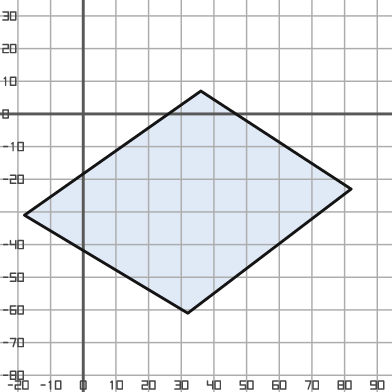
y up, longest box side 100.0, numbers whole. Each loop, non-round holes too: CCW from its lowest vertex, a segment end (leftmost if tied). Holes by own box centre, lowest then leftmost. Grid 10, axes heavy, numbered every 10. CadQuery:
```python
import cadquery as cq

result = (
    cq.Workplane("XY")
    .moveTo(32.0, -61.0)
    .lineTo(82.0, -23.0)
    .lineTo(36.0, 7.0)
    .lineTo(-18.0, -31.0)
    .close()
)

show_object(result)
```